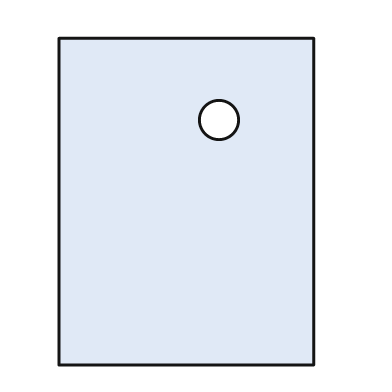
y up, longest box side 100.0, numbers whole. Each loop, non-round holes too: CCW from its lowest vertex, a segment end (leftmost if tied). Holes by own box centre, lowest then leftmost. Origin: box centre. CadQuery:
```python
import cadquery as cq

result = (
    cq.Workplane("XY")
    .moveTo(-39.0, -50.0)
    .lineTo(39.0, -50.0)
    .lineTo(39.0, 50.0)
    .lineTo(-39.0, 50.0)
    .close()
    .moveTo(10.0, 25.0)
    .circle(6.0)
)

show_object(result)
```